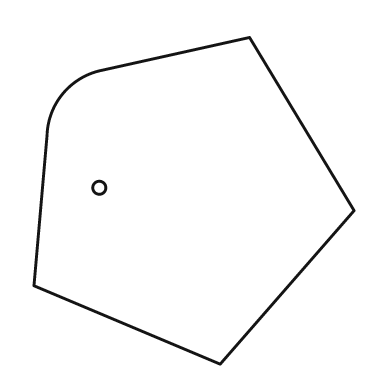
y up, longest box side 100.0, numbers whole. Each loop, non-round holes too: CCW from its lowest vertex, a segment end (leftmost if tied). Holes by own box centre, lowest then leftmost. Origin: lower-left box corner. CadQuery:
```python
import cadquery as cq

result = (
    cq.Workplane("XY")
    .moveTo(57.0, 0.0)
    .lineTo(98.0, 47.0)
    .lineTo(66.0, 100.0)
    .lineTo(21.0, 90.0)
    .threePointArc((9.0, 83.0), (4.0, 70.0))
    .lineTo(0.0, 24.0)
    .close()
    .moveTo(20.0, 54.0)
    .circle(2.0)
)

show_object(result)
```